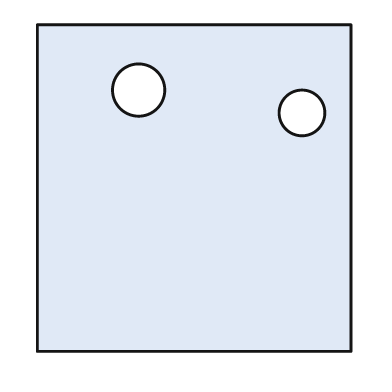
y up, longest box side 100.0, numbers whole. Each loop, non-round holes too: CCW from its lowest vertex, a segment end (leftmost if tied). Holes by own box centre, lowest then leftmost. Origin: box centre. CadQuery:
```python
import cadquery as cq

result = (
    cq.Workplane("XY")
    .moveTo(-48.0, -50.0)
    .lineTo(48.0, -50.0)
    .lineTo(48.0, 50.0)
    .lineTo(-48.0, 50.0)
    .close()
    .moveTo(33.0, 23.0)
    .circle(7.0)
    .moveTo(-17.0, 30.0)
    .circle(8.0)
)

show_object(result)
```